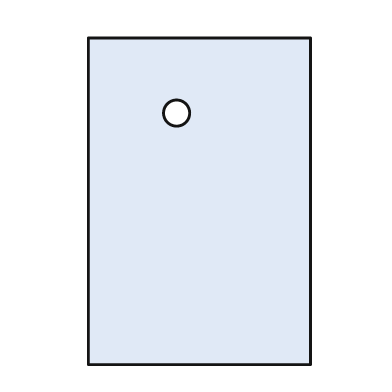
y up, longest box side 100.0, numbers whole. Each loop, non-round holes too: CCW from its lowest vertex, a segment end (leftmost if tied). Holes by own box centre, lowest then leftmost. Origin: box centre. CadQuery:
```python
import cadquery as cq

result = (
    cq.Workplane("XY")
    .moveTo(-34.0, -50.0)
    .lineTo(34.0, -50.0)
    .lineTo(34.0, 50.0)
    .lineTo(-34.0, 50.0)
    .close()
    .moveTo(-7.0, 27.0)
    .circle(4.0)
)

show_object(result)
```